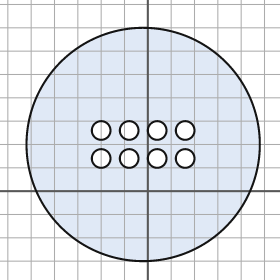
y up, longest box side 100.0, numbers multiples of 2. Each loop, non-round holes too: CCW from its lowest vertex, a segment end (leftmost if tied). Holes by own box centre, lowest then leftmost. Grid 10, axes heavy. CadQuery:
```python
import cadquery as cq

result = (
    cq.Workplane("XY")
    .moveTo(-2.0, 20.0)
    .circle(50.0)
    .moveTo(-20.0, 14.0)
    .circle(4.0)
    .moveTo(-8.0, 14.0)
    .circle(4.0)
    .moveTo(4.0, 14.0)
    .circle(4.0)
    .moveTo(16.0, 14.0)
    .circle(4.0)
    .moveTo(-20.0, 26.0)
    .circle(4.0)
    .moveTo(-8.0, 26.0)
    .circle(4.0)
    .moveTo(4.0, 26.0)
    .circle(4.0)
    .moveTo(16.0, 26.0)
    .circle(4.0)
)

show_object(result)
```